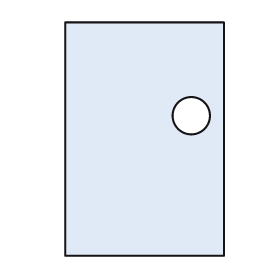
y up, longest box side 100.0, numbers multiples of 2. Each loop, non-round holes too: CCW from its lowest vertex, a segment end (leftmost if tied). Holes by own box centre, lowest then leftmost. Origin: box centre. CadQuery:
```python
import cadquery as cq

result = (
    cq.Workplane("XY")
    .moveTo(-34.0, -50.0)
    .lineTo(34.0, -50.0)
    .lineTo(34.0, 50.0)
    .lineTo(-34.0, 50.0)
    .close()
    .moveTo(20.0, 10.0)
    .circle(8.0)
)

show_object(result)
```